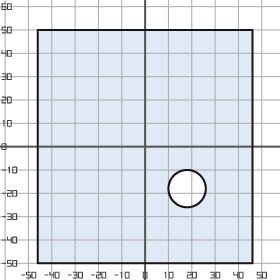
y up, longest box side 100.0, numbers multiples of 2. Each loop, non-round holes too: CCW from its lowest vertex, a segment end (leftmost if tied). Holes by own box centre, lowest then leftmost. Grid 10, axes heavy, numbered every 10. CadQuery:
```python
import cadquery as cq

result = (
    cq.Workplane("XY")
    .moveTo(-46.0, -50.0)
    .lineTo(46.0, -50.0)
    .lineTo(46.0, 50.0)
    .lineTo(-46.0, 50.0)
    .close()
    .moveTo(18.0, -18.0)
    .circle(8.0)
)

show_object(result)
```